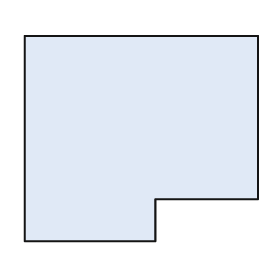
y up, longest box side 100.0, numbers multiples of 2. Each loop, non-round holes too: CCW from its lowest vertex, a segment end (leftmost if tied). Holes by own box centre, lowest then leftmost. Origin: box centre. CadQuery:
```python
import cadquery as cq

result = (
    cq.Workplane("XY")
    .moveTo(-50.0, -44.0)
    .lineTo(6.0, -44.0)
    .lineTo(6.0, -26.0)
    .lineTo(50.0, -26.0)
    .lineTo(50.0, 44.0)
    .lineTo(-50.0, 44.0)
    .close()
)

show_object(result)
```